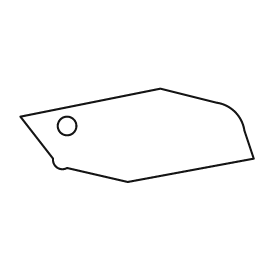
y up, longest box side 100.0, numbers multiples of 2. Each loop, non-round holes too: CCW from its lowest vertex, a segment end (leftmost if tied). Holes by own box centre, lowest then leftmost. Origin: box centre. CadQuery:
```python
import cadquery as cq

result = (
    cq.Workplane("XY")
    .moveTo(-4.0, -20.0)
    .lineTo(50.0, -10.0)
    .lineTo(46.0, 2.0)
    .threePointArc((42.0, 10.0), (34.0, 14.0))
    .lineTo(10.0, 20.0)
    .lineTo(-50.0, 8.0)
    .lineTo(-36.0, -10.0)
    .threePointArc((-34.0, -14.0), (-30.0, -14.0))
    .close()
    .moveTo(-30.0, 4.0)
    .circle(4.0)
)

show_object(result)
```